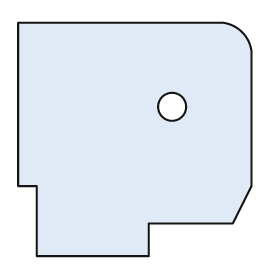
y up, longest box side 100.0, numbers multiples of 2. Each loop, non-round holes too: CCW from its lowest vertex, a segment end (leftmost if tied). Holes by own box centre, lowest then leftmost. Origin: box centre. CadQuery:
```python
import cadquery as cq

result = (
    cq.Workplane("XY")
    .moveTo(-42.0, -50.0)
    .lineTo(6.0, -50.0)
    .lineTo(6.0, -36.0)
    .lineTo(42.0, -36.0)
    .lineTo(50.0, -20.0)
    .lineTo(50.0, 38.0)
    .threePointArc((46.0, 46.0), (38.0, 50.0))
    .lineTo(-50.0, 50.0)
    .lineTo(-50.0, -20.0)
    .lineTo(-42.0, -20.0)
    .close()
    .moveTo(16.0, 14.0)
    .circle(6.0)
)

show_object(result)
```